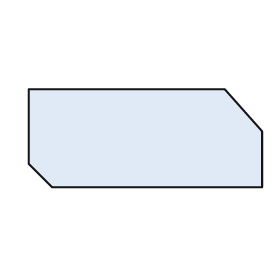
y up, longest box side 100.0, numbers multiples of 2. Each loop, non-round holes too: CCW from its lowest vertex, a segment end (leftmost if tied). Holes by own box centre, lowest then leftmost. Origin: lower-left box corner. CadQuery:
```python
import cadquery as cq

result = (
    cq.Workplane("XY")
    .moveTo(10.0, 0.0)
    .lineTo(100.0, 0.0)
    .lineTo(100.0, 24.0)
    .lineTo(84.0, 42.0)
    .lineTo(0.0, 42.0)
    .lineTo(0.0, 10.0)
    .close()
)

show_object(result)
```